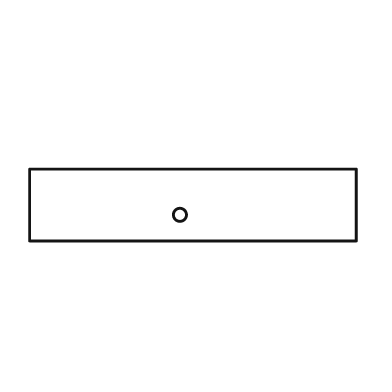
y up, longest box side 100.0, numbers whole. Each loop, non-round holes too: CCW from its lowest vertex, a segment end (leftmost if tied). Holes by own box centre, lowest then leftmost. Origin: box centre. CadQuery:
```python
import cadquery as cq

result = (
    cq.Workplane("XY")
    .moveTo(-50.0, -11.0)
    .lineTo(50.0, -11.0)
    .lineTo(50.0, 11.0)
    .lineTo(-50.0, 11.0)
    .close()
    .moveTo(-4.0, -3.0)
    .circle(2.0)
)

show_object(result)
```